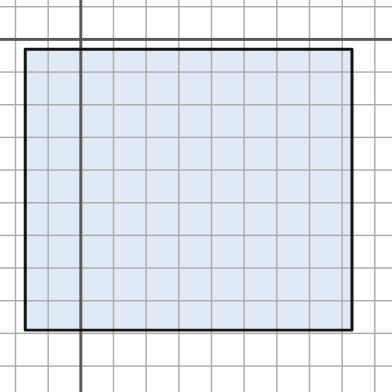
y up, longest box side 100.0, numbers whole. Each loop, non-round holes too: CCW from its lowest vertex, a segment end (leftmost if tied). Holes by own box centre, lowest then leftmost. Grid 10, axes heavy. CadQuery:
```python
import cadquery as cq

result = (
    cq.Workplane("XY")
    .moveTo(-17.0, -89.0)
    .lineTo(83.0, -89.0)
    .lineTo(83.0, -3.0)
    .lineTo(-17.0, -3.0)
    .close()
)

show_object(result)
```